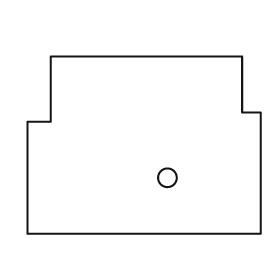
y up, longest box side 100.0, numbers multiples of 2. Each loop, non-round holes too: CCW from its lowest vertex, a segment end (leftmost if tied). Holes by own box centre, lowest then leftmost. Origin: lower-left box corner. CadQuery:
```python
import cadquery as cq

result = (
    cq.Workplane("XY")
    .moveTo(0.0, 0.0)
    .lineTo(100.0, 0.0)
    .lineTo(100.0, 52.0)
    .lineTo(92.0, 52.0)
    .lineTo(92.0, 76.0)
    .lineTo(10.0, 76.0)
    .lineTo(10.0, 48.0)
    .lineTo(0.0, 48.0)
    .close()
    .moveTo(60.0, 24.0)
    .circle(4.0)
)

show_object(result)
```